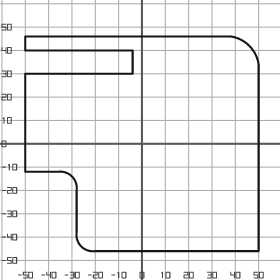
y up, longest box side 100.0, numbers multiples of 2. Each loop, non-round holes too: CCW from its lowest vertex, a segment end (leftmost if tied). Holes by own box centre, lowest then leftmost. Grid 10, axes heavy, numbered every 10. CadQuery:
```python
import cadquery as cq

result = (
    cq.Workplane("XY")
    .moveTo(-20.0, -46.0)
    .lineTo(50.0, -46.0)
    .lineTo(50.0, 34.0)
    .threePointArc((46.0, 42.0), (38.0, 46.0))
    .lineTo(-50.0, 46.0)
    .lineTo(-50.0, 40.0)
    .lineTo(-4.0, 40.0)
    .lineTo(-4.0, 30.0)
    .lineTo(-50.0, 30.0)
    .lineTo(-50.0, -12.0)
    .lineTo(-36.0, -12.0)
    .threePointArc((-30.0, -14.0), (-28.0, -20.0))
    .lineTo(-28.0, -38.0)
    .threePointArc((-26.0, -44.0), (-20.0, -46.0))
    .close()
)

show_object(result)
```